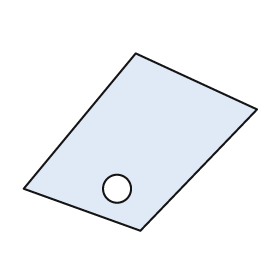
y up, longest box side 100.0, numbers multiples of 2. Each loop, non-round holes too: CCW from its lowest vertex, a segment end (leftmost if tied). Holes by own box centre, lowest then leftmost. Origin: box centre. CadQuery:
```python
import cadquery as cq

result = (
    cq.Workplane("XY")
    .moveTo(0.0, -38.0)
    .lineTo(50.0, 14.0)
    .lineTo(-2.0, 38.0)
    .lineTo(-50.0, -20.0)
    .close()
    .moveTo(-10.0, -20.0)
    .circle(6.0)
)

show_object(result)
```